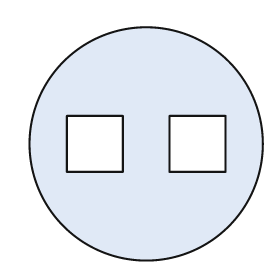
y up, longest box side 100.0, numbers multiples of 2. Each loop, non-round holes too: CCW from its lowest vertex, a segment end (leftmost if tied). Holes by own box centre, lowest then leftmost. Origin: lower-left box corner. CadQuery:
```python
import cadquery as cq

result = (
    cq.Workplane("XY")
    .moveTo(50.0, 50.0)
    .circle(50.0)
    .moveTo(16.0, 38.0)
    .lineTo(40.0, 38.0)
    .lineTo(40.0, 62.0)
    .lineTo(16.0, 62.0)
    .close()
    .moveTo(60.0, 38.0)
    .lineTo(84.0, 38.0)
    .lineTo(84.0, 62.0)
    .lineTo(60.0, 62.0)
    .close()
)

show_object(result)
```